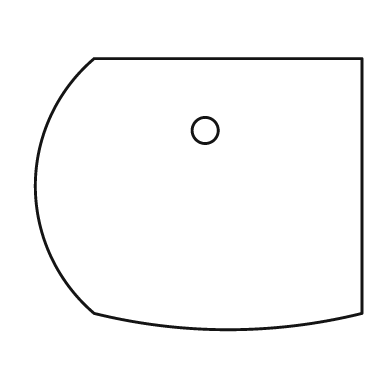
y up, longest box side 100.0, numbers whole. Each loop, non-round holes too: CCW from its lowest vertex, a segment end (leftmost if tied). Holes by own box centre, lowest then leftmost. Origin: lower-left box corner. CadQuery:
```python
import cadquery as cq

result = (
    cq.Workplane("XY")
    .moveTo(18.0, 5.0)
    .threePointArc((59.0, 0.0), (100.0, 5.0))
    .lineTo(100.0, 83.0)
    .lineTo(18.0, 83.0)
    .threePointArc((0.0, 44.0), (18.0, 5.0))
    .close()
    .moveTo(52.0, 61.0)
    .circle(4.0)
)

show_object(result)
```